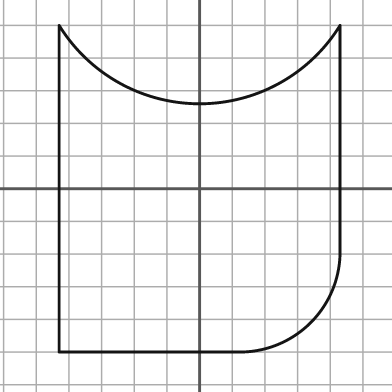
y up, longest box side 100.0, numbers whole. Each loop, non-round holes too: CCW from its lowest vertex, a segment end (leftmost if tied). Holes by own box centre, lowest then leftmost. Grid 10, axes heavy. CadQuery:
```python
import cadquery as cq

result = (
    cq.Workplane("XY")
    .moveTo(-43.0, -50.0)
    .lineTo(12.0, -50.0)
    .threePointArc((34.0, -41.0), (43.0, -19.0))
    .lineTo(43.0, 50.0)
    .threePointArc((0.0, 26.0), (-43.0, 50.0))
    .close()
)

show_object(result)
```